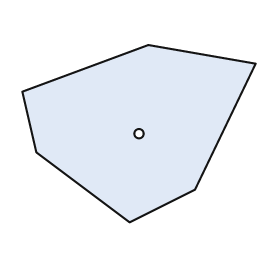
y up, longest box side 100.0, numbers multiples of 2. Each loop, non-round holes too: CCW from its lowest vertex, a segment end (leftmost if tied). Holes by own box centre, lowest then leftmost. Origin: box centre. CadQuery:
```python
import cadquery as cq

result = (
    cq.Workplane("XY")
    .moveTo(-4.0, -38.0)
    .lineTo(24.0, -24.0)
    .lineTo(50.0, 30.0)
    .lineTo(4.0, 38.0)
    .lineTo(-50.0, 18.0)
    .lineTo(-44.0, -8.0)
    .close()
    .moveTo(0.0, 0.0)
    .circle(2.0)
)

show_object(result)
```